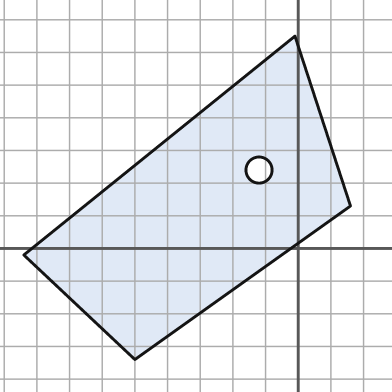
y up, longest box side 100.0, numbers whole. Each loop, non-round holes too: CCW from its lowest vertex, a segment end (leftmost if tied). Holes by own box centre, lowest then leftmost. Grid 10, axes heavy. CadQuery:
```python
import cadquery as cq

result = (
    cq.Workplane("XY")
    .moveTo(-50.0, -34.0)
    .lineTo(16.0, 13.0)
    .lineTo(-1.0, 65.0)
    .lineTo(-84.0, -2.0)
    .close()
    .moveTo(-12.0, 24.0)
    .circle(4.0)
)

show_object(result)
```